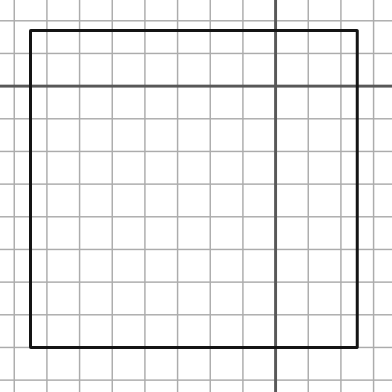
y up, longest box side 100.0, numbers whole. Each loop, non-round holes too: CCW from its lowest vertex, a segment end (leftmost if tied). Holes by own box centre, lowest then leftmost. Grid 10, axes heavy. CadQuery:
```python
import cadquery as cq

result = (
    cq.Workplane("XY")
    .moveTo(-75.0, -80.0)
    .lineTo(25.0, -80.0)
    .lineTo(25.0, 17.0)
    .lineTo(-75.0, 17.0)
    .close()
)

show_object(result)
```